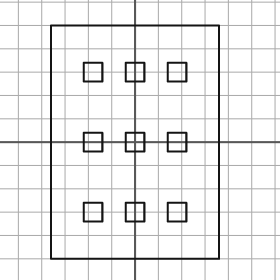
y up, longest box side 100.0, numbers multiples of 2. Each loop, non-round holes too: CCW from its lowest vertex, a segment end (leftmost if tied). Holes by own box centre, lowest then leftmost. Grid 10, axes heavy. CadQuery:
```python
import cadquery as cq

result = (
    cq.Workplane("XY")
    .moveTo(-36.0, -50.0)
    .lineTo(36.0, -50.0)
    .lineTo(36.0, 50.0)
    .lineTo(-36.0, 50.0)
    .close()
    .moveTo(-22.0, -34.0)
    .lineTo(-14.0, -34.0)
    .lineTo(-14.0, -26.0)
    .lineTo(-22.0, -26.0)
    .close()
    .moveTo(-4.0, -34.0)
    .lineTo(4.0, -34.0)
    .lineTo(4.0, -26.0)
    .lineTo(-4.0, -26.0)
    .close()
    .moveTo(14.0, -34.0)
    .lineTo(22.0, -34.0)
    .lineTo(22.0, -26.0)
    .lineTo(14.0, -26.0)
    .close()
    .moveTo(-22.0, -4.0)
    .lineTo(-14.0, -4.0)
    .lineTo(-14.0, 4.0)
    .lineTo(-22.0, 4.0)
    .close()
    .moveTo(-4.0, -4.0)
    .lineTo(4.0, -4.0)
    .lineTo(4.0, 4.0)
    .lineTo(-4.0, 4.0)
    .close()
    .moveTo(14.0, -4.0)
    .lineTo(22.0, -4.0)
    .lineTo(22.0, 4.0)
    .lineTo(14.0, 4.0)
    .close()
    .moveTo(-22.0, 26.0)
    .lineTo(-14.0, 26.0)
    .lineTo(-14.0, 34.0)
    .lineTo(-22.0, 34.0)
    .close()
    .moveTo(-4.0, 26.0)
    .lineTo(4.0, 26.0)
    .lineTo(4.0, 34.0)
    .lineTo(-4.0, 34.0)
    .close()
    .moveTo(14.0, 26.0)
    .lineTo(22.0, 26.0)
    .lineTo(22.0, 34.0)
    .lineTo(14.0, 34.0)
    .close()
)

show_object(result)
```